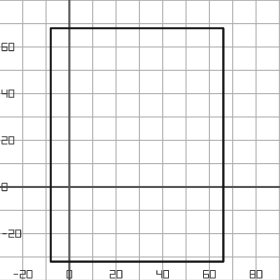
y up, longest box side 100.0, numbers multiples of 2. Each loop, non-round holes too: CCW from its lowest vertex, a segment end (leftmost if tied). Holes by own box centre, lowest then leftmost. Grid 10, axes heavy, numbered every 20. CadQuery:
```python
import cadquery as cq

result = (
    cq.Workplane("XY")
    .moveTo(-8.0, -32.0)
    .lineTo(66.0, -32.0)
    .lineTo(66.0, 68.0)
    .lineTo(-8.0, 68.0)
    .close()
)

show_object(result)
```